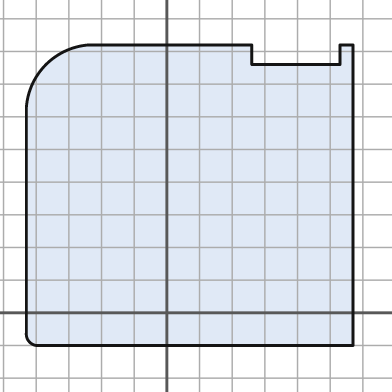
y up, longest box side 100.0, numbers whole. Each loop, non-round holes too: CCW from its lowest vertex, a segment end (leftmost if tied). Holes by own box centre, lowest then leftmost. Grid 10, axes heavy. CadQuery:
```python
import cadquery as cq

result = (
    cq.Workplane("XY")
    .moveTo(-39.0, -10.0)
    .lineTo(57.0, -10.0)
    .lineTo(57.0, 82.0)
    .lineTo(53.0, 82.0)
    .lineTo(53.0, 76.0)
    .lineTo(26.0, 76.0)
    .lineTo(26.0, 82.0)
    .lineTo(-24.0, 82.0)
    .threePointArc((-37.0, 76.0), (-43.0, 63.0))
    .lineTo(-43.0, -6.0)
    .threePointArc((-42.0, -9.0), (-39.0, -10.0))
    .close()
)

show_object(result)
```